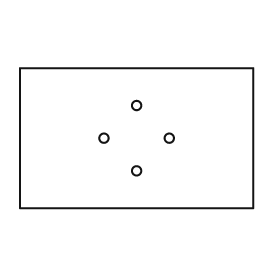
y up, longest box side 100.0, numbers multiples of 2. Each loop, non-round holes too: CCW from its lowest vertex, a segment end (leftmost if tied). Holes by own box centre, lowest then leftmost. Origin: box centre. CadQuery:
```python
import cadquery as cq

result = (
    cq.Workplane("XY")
    .moveTo(-50.0, -30.0)
    .lineTo(50.0, -30.0)
    .lineTo(50.0, 30.0)
    .lineTo(-50.0, 30.0)
    .close()
    .moveTo(0.0, -14.0)
    .circle(2.0)
    .moveTo(-14.0, 0.0)
    .circle(2.0)
    .moveTo(14.0, 0.0)
    .circle(2.0)
    .moveTo(0.0, 14.0)
    .circle(2.0)
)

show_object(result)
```